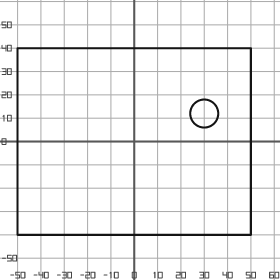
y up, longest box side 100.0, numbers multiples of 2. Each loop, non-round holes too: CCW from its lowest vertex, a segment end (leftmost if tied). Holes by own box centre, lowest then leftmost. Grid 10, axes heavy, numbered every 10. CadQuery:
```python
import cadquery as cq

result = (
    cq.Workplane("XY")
    .moveTo(-50.0, -40.0)
    .lineTo(50.0, -40.0)
    .lineTo(50.0, 40.0)
    .lineTo(-50.0, 40.0)
    .close()
    .moveTo(30.0, 12.0)
    .circle(6.0)
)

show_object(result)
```